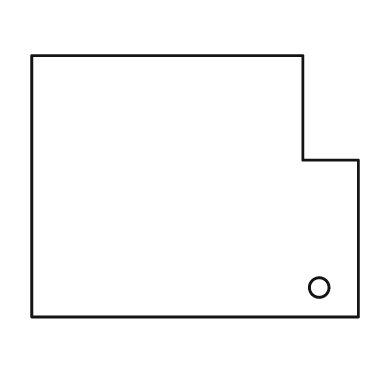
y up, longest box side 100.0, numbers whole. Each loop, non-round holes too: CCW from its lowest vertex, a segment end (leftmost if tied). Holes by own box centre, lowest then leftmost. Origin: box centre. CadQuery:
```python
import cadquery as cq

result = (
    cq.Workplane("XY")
    .moveTo(-50.0, -40.0)
    .lineTo(50.0, -40.0)
    .lineTo(50.0, 8.0)
    .lineTo(33.0, 8.0)
    .lineTo(33.0, 40.0)
    .lineTo(-50.0, 40.0)
    .close()
    .moveTo(38.0, -31.0)
    .circle(3.0)
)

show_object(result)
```